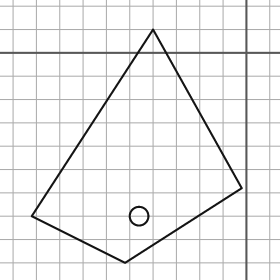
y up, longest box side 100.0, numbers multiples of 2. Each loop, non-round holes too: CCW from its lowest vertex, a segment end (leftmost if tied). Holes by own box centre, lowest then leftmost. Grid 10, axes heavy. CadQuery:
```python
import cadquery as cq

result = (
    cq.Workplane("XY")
    .moveTo(-52.0, -90.0)
    .lineTo(-2.0, -58.0)
    .lineTo(-40.0, 10.0)
    .lineTo(-92.0, -70.0)
    .close()
    .moveTo(-46.0, -70.0)
    .circle(4.0)
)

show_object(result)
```